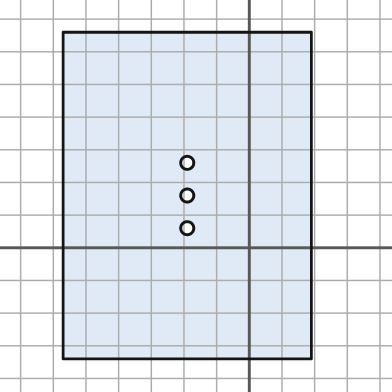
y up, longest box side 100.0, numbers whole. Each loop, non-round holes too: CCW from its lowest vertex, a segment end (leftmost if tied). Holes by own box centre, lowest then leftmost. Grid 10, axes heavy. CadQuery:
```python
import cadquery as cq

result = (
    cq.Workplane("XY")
    .moveTo(-57.0, -34.0)
    .lineTo(19.0, -34.0)
    .lineTo(19.0, 66.0)
    .lineTo(-57.0, 66.0)
    .close()
    .moveTo(-19.0, 6.0)
    .circle(2.0)
    .moveTo(-19.0, 16.0)
    .circle(2.0)
    .moveTo(-19.0, 26.0)
    .circle(2.0)
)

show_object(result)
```